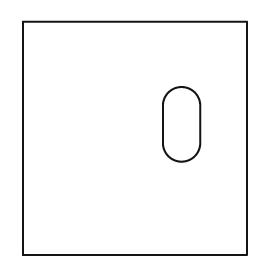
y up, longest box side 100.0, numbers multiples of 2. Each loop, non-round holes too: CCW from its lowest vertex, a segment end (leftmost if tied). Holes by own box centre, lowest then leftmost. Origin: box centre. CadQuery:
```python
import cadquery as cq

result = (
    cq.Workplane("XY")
    .moveTo(-48.0, -50.0)
    .lineTo(48.0, -50.0)
    .lineTo(48.0, 50.0)
    .lineTo(-48.0, 50.0)
    .close()
    .moveTo(12.0, -2.0)
    .threePointArc((20.0, -10.0), (28.0, -2.0))
    .lineTo(28.0, 14.0)
    .threePointArc((20.0, 22.0), (12.0, 14.0))
    .close()
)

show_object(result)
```